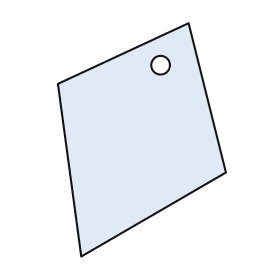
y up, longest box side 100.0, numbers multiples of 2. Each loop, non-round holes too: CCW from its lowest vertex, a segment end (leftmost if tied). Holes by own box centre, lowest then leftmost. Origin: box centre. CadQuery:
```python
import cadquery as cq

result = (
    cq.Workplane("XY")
    .moveTo(-26.0, -50.0)
    .lineTo(36.0, -14.0)
    .lineTo(20.0, 50.0)
    .lineTo(-36.0, 24.0)
    .close()
    .moveTo(8.0, 32.0)
    .circle(4.0)
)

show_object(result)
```